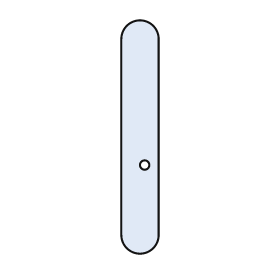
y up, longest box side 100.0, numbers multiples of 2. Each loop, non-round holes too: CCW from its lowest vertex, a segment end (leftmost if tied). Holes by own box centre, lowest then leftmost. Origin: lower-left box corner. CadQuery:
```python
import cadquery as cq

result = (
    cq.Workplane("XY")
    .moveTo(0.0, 8.0)
    .threePointArc((8.0, 0.0), (16.0, 8.0))
    .lineTo(16.0, 92.0)
    .threePointArc((8.0, 100.0), (0.0, 92.0))
    .close()
    .moveTo(10.0, 38.0)
    .circle(2.0)
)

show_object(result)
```